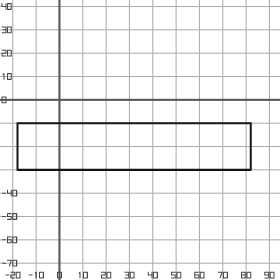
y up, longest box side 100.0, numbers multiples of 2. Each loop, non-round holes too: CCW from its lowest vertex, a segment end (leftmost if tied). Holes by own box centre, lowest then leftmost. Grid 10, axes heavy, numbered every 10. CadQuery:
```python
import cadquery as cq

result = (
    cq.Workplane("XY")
    .moveTo(-18.0, -30.0)
    .lineTo(82.0, -30.0)
    .lineTo(82.0, -10.0)
    .lineTo(-18.0, -10.0)
    .close()
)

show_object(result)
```